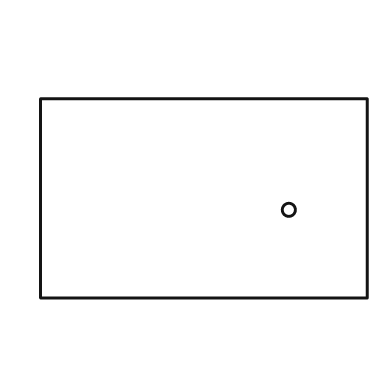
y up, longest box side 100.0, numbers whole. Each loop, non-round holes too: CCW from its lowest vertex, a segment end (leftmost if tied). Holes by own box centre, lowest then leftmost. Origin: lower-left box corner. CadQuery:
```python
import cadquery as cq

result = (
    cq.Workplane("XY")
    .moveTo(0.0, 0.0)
    .lineTo(100.0, 0.0)
    .lineTo(100.0, 61.0)
    .lineTo(0.0, 61.0)
    .close()
    .moveTo(76.0, 27.0)
    .circle(2.0)
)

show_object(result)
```